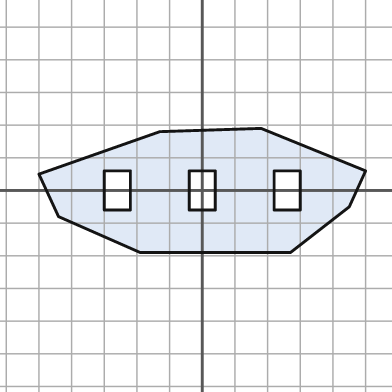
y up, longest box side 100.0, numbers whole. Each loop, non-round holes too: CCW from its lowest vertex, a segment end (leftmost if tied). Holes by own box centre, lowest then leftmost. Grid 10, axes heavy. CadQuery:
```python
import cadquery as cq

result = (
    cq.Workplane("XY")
    .moveTo(-19.0, -19.0)
    .lineTo(27.0, -19.0)
    .lineTo(45.0, -5.0)
    .lineTo(50.0, 6.0)
    .lineTo(18.0, 19.0)
    .lineTo(-13.0, 18.0)
    .lineTo(-50.0, 5.0)
    .lineTo(-44.0, -8.0)
    .close()
    .moveTo(-30.0, -6.0)
    .lineTo(-22.0, -6.0)
    .lineTo(-22.0, 6.0)
    .lineTo(-30.0, 6.0)
    .close()
    .moveTo(-4.0, -6.0)
    .lineTo(4.0, -6.0)
    .lineTo(4.0, 6.0)
    .lineTo(-4.0, 6.0)
    .close()
    .moveTo(22.0, -6.0)
    .lineTo(30.0, -6.0)
    .lineTo(30.0, 6.0)
    .lineTo(22.0, 6.0)
    .close()
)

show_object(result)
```